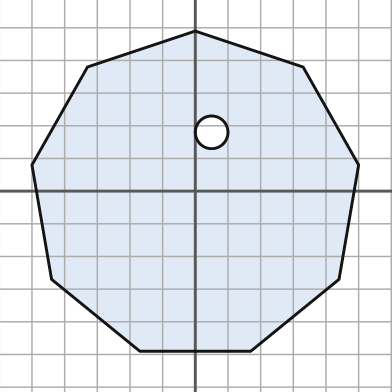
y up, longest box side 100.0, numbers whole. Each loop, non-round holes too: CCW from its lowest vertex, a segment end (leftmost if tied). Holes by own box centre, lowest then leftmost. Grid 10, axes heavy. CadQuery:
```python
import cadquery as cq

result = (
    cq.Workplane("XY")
    .moveTo(-17.0, -49.0)
    .lineTo(17.0, -49.0)
    .lineTo(44.0, -27.0)
    .lineTo(50.0, 8.0)
    .lineTo(33.0, 38.0)
    .lineTo(0.0, 49.0)
    .lineTo(-33.0, 38.0)
    .lineTo(-50.0, 8.0)
    .lineTo(-44.0, -27.0)
    .close()
    .moveTo(5.0, 18.0)
    .circle(5.0)
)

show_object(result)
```